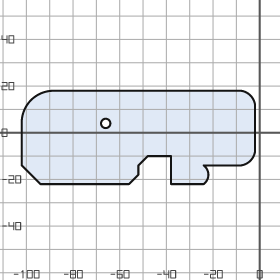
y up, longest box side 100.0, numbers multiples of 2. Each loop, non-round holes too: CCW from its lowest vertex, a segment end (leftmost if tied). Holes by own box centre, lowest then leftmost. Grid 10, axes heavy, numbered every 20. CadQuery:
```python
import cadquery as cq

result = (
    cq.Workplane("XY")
    .moveTo(-94.0, -22.0)
    .lineTo(-56.0, -22.0)
    .lineTo(-52.0, -18.0)
    .lineTo(-52.0, -14.0)
    .lineTo(-48.0, -10.0)
    .lineTo(-38.0, -10.0)
    .lineTo(-38.0, -22.0)
    .lineTo(-24.0, -22.0)
    .threePointArc((-22.0, -18.0), (-24.0, -14.0))
    .lineTo(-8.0, -14.0)
    .threePointArc((-4.0, -12.0), (-2.0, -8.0))
    .lineTo(-2.0, 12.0)
    .threePointArc((-4.0, 16.0), (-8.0, 18.0))
    .lineTo(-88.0, 18.0)
    .threePointArc((-98.0, 14.0), (-102.0, 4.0))
    .lineTo(-102.0, -14.0)
    .close()
    .moveTo(-66.0, 4.0)
    .circle(2.0)
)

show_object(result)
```